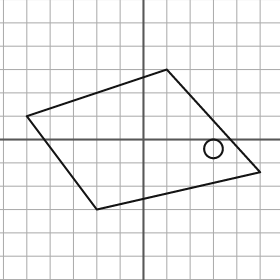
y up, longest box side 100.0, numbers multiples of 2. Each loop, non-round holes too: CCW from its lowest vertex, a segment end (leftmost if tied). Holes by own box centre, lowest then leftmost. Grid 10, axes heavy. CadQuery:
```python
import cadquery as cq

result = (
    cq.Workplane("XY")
    .moveTo(-20.0, -30.0)
    .lineTo(50.0, -14.0)
    .lineTo(10.0, 30.0)
    .lineTo(-50.0, 10.0)
    .close()
    .moveTo(30.0, -4.0)
    .circle(4.0)
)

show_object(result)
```